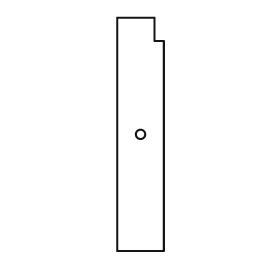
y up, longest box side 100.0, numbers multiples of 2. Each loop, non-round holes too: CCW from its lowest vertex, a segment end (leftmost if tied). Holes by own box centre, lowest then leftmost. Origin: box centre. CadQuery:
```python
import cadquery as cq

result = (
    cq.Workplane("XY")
    .moveTo(-10.0, -50.0)
    .lineTo(10.0, -50.0)
    .lineTo(10.0, 40.0)
    .lineTo(6.0, 40.0)
    .lineTo(6.0, 50.0)
    .lineTo(-10.0, 50.0)
    .close()
    .moveTo(0.0, 0.0)
    .circle(2.0)
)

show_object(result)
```